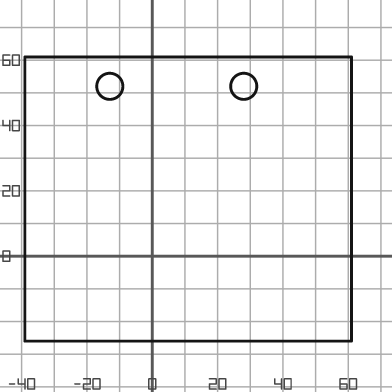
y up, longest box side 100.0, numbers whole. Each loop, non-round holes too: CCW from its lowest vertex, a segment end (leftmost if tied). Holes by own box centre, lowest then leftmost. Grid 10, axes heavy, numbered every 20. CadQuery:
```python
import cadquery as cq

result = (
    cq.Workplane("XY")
    .moveTo(-39.0, -26.0)
    .lineTo(61.0, -26.0)
    .lineTo(61.0, 61.0)
    .lineTo(-39.0, 61.0)
    .close()
    .moveTo(-13.0, 52.0)
    .circle(4.0)
    .moveTo(28.0, 52.0)
    .circle(4.0)
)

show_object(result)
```